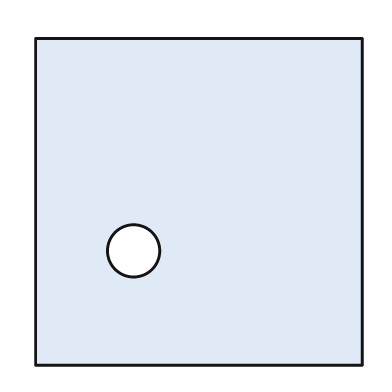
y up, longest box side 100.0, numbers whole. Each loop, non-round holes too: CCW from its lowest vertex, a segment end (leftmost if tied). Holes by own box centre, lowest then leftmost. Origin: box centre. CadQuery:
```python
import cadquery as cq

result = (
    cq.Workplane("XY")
    .moveTo(-50.0, -50.0)
    .lineTo(50.0, -50.0)
    .lineTo(50.0, 50.0)
    .lineTo(-50.0, 50.0)
    .close()
    .moveTo(-20.0, -15.0)
    .circle(8.0)
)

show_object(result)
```